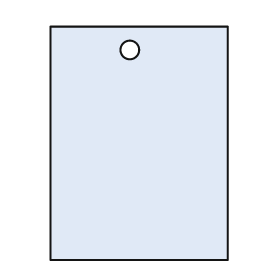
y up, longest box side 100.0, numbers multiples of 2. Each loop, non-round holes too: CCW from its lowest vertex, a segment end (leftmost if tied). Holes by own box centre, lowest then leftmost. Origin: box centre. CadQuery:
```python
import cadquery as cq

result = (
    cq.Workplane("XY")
    .moveTo(-38.0, -50.0)
    .lineTo(38.0, -50.0)
    .lineTo(38.0, 50.0)
    .lineTo(-38.0, 50.0)
    .close()
    .moveTo(-4.0, 40.0)
    .circle(4.0)
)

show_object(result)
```